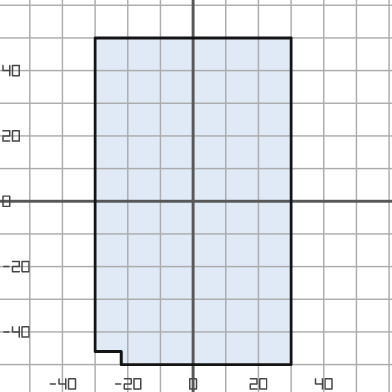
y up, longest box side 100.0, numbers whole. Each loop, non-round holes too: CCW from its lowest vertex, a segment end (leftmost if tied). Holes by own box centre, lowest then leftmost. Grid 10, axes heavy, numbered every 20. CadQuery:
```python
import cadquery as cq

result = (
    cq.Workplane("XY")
    .moveTo(-22.0, -50.0)
    .lineTo(30.0, -50.0)
    .lineTo(30.0, 50.0)
    .lineTo(-30.0, 50.0)
    .lineTo(-30.0, -46.0)
    .lineTo(-22.0, -46.0)
    .close()
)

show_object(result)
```